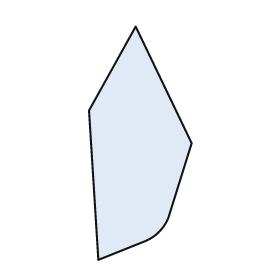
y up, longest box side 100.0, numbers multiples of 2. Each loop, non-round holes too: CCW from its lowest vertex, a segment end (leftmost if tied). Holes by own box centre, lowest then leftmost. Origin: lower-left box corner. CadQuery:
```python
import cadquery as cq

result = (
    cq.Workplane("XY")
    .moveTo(4.0, 0.0)
    .lineTo(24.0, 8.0)
    .threePointArc((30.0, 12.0), (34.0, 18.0))
    .lineTo(44.0, 50.0)
    .lineTo(20.0, 100.0)
    .lineTo(0.0, 64.0)
    .close()
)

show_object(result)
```